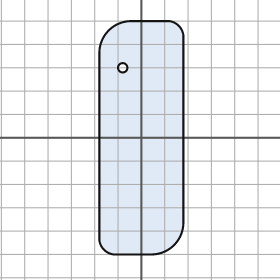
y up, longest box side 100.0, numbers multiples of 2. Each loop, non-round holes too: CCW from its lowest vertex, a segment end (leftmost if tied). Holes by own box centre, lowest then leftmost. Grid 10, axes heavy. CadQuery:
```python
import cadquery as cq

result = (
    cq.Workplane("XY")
    .moveTo(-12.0, -50.0)
    .lineTo(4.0, -50.0)
    .threePointArc((14.0, -46.0), (18.0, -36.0))
    .lineTo(18.0, 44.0)
    .threePointArc((16.0, 48.0), (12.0, 50.0))
    .lineTo(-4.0, 50.0)
    .threePointArc((-14.0, 46.0), (-18.0, 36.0))
    .lineTo(-18.0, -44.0)
    .threePointArc((-16.0, -48.0), (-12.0, -50.0))
    .close()
    .moveTo(-8.0, 30.0)
    .circle(2.0)
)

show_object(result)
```